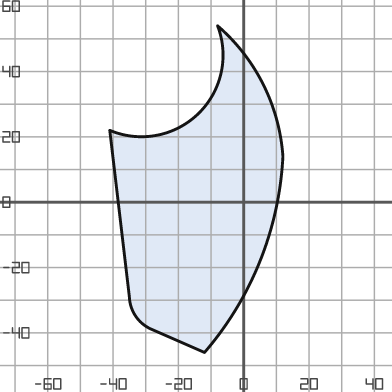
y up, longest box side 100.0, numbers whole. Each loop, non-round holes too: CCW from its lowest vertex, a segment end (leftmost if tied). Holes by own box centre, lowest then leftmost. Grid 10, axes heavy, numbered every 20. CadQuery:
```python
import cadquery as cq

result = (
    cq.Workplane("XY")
    .moveTo(-12.0, -46.0)
    .threePointArc((5.0, -18.0), (12.0, 14.0))
    .threePointArc((6.0, 36.0), (-8.0, 54.0))
    .threePointArc((-14.0, 27.0), (-41.0, 22.0))
    .lineTo(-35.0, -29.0)
    .threePointArc((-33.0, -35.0), (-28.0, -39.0))
    .close()
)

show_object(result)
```